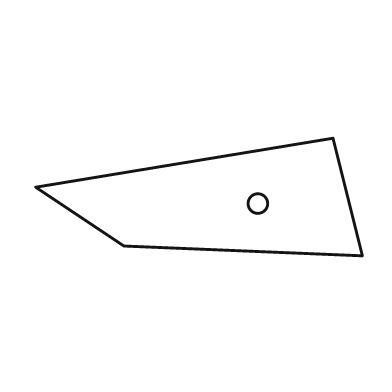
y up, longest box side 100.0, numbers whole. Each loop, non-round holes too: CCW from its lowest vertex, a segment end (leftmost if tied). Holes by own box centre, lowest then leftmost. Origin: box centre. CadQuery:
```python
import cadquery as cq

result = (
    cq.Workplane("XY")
    .moveTo(50.0, -18.0)
    .lineTo(41.0, 18.0)
    .lineTo(-50.0, 3.0)
    .lineTo(-23.0, -15.0)
    .close()
    .moveTo(18.0, -2.0)
    .circle(3.0)
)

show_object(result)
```